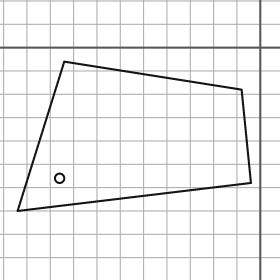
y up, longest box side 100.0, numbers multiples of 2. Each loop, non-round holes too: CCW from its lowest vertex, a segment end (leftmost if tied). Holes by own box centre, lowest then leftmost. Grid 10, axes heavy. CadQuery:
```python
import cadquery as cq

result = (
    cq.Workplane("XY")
    .moveTo(-104.0, -70.0)
    .lineTo(-4.0, -58.0)
    .lineTo(-8.0, -18.0)
    .lineTo(-84.0, -6.0)
    .close()
    .moveTo(-86.0, -56.0)
    .circle(2.0)
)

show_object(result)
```